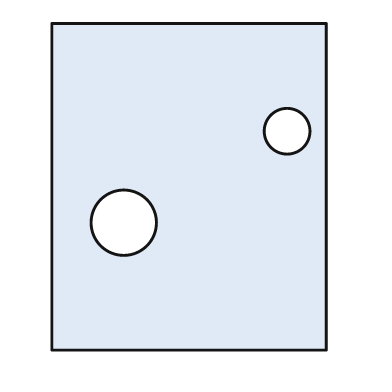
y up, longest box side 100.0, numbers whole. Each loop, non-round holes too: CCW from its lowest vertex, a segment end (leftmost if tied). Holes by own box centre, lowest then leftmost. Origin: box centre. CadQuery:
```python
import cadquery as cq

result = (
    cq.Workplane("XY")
    .moveTo(-42.0, -50.0)
    .lineTo(42.0, -50.0)
    .lineTo(42.0, 50.0)
    .lineTo(-42.0, 50.0)
    .close()
    .moveTo(-20.0, -11.0)
    .circle(10.0)
    .moveTo(30.0, 17.0)
    .circle(7.0)
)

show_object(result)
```